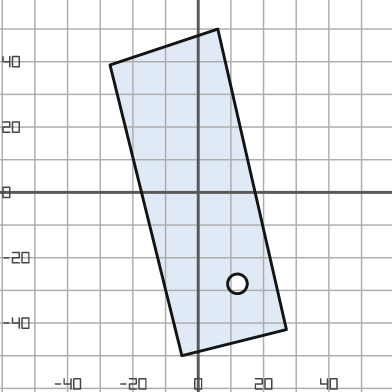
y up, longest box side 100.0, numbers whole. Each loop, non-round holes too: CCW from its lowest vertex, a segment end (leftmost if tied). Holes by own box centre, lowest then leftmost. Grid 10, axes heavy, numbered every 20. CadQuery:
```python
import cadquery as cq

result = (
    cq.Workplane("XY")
    .moveTo(-5.0, -50.0)
    .lineTo(27.0, -42.0)
    .lineTo(6.0, 50.0)
    .lineTo(-27.0, 39.0)
    .close()
    .moveTo(12.0, -28.0)
    .circle(3.0)
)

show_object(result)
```